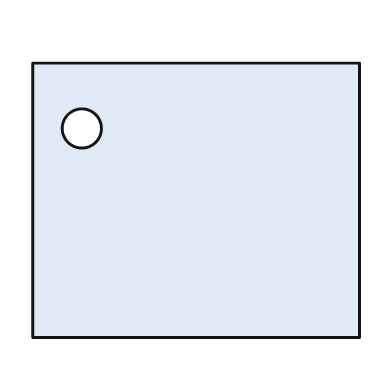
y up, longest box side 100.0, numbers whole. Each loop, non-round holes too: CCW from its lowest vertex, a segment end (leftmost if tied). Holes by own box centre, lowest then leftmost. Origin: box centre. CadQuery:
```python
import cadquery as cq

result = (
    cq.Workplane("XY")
    .moveTo(-50.0, -42.0)
    .lineTo(50.0, -42.0)
    .lineTo(50.0, 42.0)
    .lineTo(-50.0, 42.0)
    .close()
    .moveTo(-35.0, 22.0)
    .circle(6.0)
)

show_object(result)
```